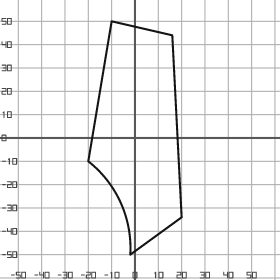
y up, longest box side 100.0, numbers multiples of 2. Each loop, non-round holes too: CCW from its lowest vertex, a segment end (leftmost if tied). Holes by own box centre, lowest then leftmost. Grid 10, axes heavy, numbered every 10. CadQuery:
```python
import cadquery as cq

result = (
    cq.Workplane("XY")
    .moveTo(-2.0, -50.0)
    .lineTo(20.0, -34.0)
    .lineTo(16.0, 44.0)
    .lineTo(-10.0, 50.0)
    .lineTo(-20.0, -10.0)
    .threePointArc((-6.0, -28.0), (-2.0, -50.0))
    .close()
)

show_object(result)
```